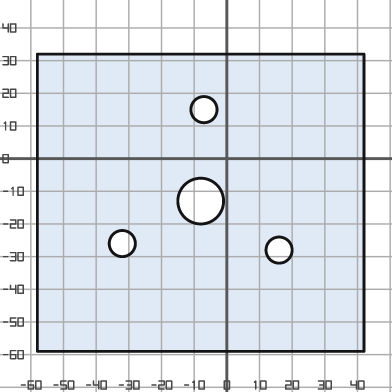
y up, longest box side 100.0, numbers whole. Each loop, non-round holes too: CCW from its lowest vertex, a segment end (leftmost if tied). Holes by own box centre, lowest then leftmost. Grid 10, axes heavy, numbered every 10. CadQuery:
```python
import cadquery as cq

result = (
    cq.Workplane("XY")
    .moveTo(-58.0, -59.0)
    .lineTo(42.0, -59.0)
    .lineTo(42.0, 32.0)
    .lineTo(-58.0, 32.0)
    .close()
    .moveTo(16.0, -28.0)
    .circle(4.0)
    .moveTo(-32.0, -26.0)
    .circle(4.0)
    .moveTo(-8.0, -13.0)
    .circle(7.0)
    .moveTo(-7.0, 15.0)
    .circle(4.0)
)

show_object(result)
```